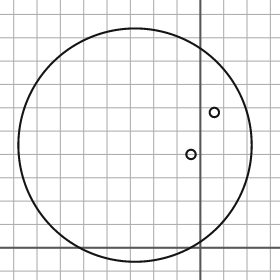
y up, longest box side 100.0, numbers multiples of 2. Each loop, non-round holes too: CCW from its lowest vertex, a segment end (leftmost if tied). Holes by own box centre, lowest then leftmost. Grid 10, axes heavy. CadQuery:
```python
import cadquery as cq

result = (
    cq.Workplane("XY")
    .moveTo(-28.0, 44.0)
    .circle(50.0)
    .moveTo(-4.0, 40.0)
    .circle(2.0)
    .moveTo(6.0, 58.0)
    .circle(2.0)
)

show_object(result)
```